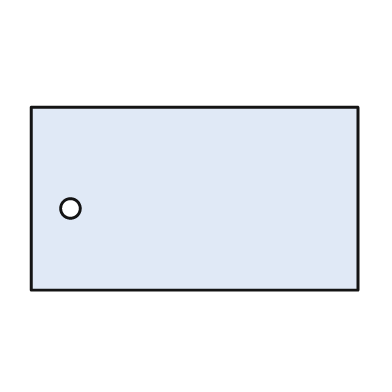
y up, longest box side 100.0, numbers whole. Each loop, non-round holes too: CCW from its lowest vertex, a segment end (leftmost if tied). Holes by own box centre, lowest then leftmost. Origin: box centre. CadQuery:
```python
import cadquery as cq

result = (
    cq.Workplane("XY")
    .moveTo(-50.0, -28.0)
    .lineTo(50.0, -28.0)
    .lineTo(50.0, 28.0)
    .lineTo(-50.0, 28.0)
    .close()
    .moveTo(-38.0, -3.0)
    .circle(3.0)
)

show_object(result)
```